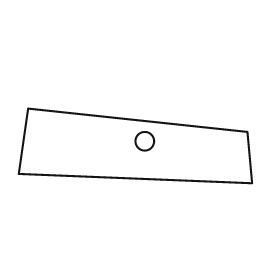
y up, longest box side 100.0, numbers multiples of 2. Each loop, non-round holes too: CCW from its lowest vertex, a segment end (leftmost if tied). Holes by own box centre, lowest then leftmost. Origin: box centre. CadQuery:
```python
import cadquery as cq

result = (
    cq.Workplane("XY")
    .moveTo(50.0, -16.0)
    .lineTo(48.0, 6.0)
    .lineTo(-46.0, 16.0)
    .lineTo(-50.0, -12.0)
    .close()
    .moveTo(4.0, 2.0)
    .circle(4.0)
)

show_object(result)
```